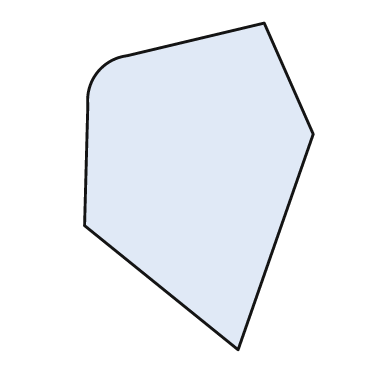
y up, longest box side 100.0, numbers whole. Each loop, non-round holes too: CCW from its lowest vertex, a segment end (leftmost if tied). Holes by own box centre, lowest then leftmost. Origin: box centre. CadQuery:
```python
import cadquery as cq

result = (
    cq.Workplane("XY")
    .moveTo(12.0, -50.0)
    .lineTo(35.0, 16.0)
    .lineTo(20.0, 50.0)
    .lineTo(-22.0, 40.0)
    .threePointArc((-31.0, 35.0), (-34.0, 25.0))
    .lineTo(-35.0, -12.0)
    .close()
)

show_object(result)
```